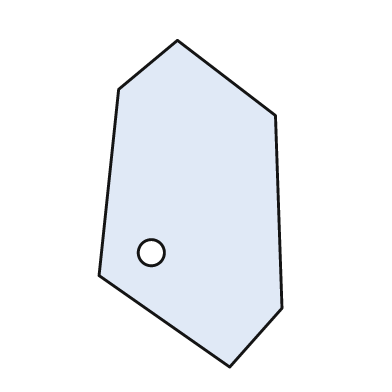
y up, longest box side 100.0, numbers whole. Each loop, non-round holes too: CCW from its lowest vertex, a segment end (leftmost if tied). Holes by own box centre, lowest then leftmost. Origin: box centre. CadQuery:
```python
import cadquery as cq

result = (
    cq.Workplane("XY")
    .moveTo(12.0, -50.0)
    .lineTo(28.0, -32.0)
    .lineTo(26.0, 27.0)
    .lineTo(-4.0, 50.0)
    .lineTo(-22.0, 35.0)
    .lineTo(-28.0, -22.0)
    .close()
    .moveTo(-12.0, -15.0)
    .circle(4.0)
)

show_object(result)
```